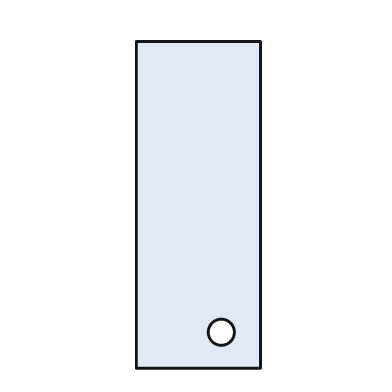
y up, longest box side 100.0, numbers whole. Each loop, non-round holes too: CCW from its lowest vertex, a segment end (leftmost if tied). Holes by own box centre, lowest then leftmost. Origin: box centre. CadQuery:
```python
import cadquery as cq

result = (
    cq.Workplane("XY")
    .moveTo(-19.0, -50.0)
    .lineTo(19.0, -50.0)
    .lineTo(19.0, 50.0)
    .lineTo(-19.0, 50.0)
    .close()
    .moveTo(7.0, -39.0)
    .circle(4.0)
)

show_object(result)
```